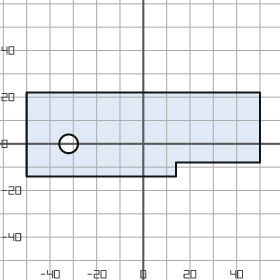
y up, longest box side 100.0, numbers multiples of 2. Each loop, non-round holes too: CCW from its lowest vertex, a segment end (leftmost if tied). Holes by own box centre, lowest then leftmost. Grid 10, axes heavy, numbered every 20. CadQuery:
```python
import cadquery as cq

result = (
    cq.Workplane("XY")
    .moveTo(-50.0, -14.0)
    .lineTo(14.0, -14.0)
    .lineTo(14.0, -8.0)
    .lineTo(50.0, -8.0)
    .lineTo(50.0, 22.0)
    .lineTo(-50.0, 22.0)
    .close()
    .moveTo(-32.0, 0.0)
    .circle(4.0)
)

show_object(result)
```